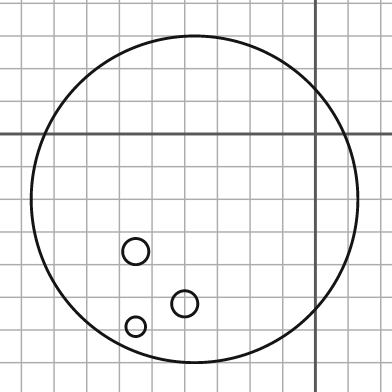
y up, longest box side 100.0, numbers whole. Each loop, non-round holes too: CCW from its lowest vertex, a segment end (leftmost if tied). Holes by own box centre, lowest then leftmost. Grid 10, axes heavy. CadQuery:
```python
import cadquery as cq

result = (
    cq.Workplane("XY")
    .moveTo(-37.0, -20.0)
    .circle(50.0)
    .moveTo(-55.0, -59.0)
    .circle(3.0)
    .moveTo(-40.0, -52.0)
    .circle(4.0)
    .moveTo(-55.0, -36.0)
    .circle(4.0)
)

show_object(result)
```